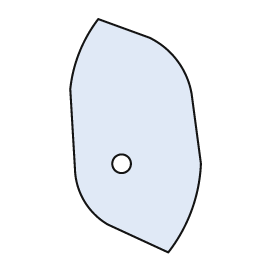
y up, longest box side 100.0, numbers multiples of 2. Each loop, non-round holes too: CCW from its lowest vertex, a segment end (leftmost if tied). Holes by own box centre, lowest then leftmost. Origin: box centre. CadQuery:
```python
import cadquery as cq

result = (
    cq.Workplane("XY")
    .moveTo(14.0, -50.0)
    .threePointArc((24.0, -32.0), (28.0, -12.0))
    .lineTo(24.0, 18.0)
    .threePointArc((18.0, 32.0), (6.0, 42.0))
    .lineTo(-16.0, 50.0)
    .threePointArc((-24.0, 36.0), (-28.0, 20.0))
    .lineTo(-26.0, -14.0)
    .threePointArc((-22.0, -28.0), (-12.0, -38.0))
    .close()
    .moveTo(-6.0, -12.0)
    .circle(4.0)
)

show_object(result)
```